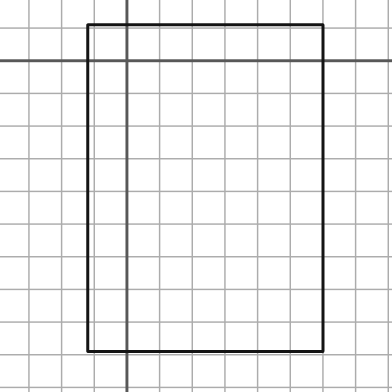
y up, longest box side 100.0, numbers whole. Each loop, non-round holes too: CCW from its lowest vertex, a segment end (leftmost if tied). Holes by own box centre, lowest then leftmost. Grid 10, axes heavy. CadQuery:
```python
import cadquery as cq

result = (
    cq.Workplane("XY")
    .moveTo(-12.0, -89.0)
    .lineTo(60.0, -89.0)
    .lineTo(60.0, 11.0)
    .lineTo(-12.0, 11.0)
    .close()
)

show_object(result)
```